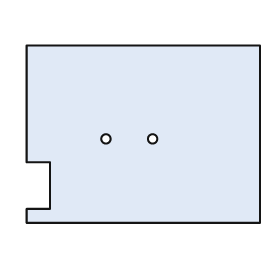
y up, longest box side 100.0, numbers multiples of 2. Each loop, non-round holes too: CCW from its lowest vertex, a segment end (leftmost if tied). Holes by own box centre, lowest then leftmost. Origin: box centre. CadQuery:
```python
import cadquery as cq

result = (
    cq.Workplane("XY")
    .moveTo(-50.0, -38.0)
    .lineTo(50.0, -38.0)
    .lineTo(50.0, 38.0)
    .lineTo(-50.0, 38.0)
    .lineTo(-50.0, -12.0)
    .lineTo(-40.0, -12.0)
    .lineTo(-40.0, -32.0)
    .lineTo(-50.0, -32.0)
    .close()
    .moveTo(-16.0, -2.0)
    .circle(2.0)
    .moveTo(4.0, -2.0)
    .circle(2.0)
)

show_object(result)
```